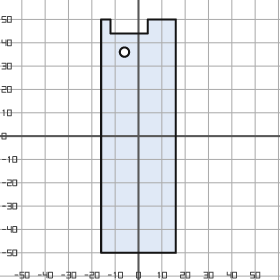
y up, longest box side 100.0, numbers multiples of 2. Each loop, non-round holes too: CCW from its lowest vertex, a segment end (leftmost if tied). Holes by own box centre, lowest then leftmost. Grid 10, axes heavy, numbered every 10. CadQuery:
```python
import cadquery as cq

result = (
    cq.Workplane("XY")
    .moveTo(-16.0, -50.0)
    .lineTo(16.0, -50.0)
    .lineTo(16.0, 50.0)
    .lineTo(4.0, 50.0)
    .lineTo(4.0, 44.0)
    .lineTo(-12.0, 44.0)
    .lineTo(-12.0, 50.0)
    .lineTo(-16.0, 50.0)
    .close()
    .moveTo(-6.0, 36.0)
    .circle(2.0)
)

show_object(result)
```